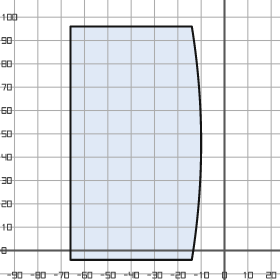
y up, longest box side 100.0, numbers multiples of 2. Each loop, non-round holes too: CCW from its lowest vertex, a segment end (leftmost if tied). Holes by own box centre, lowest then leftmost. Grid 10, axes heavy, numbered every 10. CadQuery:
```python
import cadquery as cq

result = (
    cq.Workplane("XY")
    .moveTo(-66.0, -4.0)
    .lineTo(-14.0, -4.0)
    .threePointArc((-10.0, 46.0), (-14.0, 96.0))
    .lineTo(-66.0, 96.0)
    .close()
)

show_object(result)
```